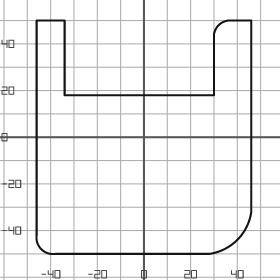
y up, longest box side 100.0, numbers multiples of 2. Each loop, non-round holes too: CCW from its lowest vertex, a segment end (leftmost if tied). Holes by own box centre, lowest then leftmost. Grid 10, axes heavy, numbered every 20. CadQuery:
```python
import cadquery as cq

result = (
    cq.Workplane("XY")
    .moveTo(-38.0, -50.0)
    .lineTo(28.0, -50.0)
    .threePointArc((40.0, -44.0), (46.0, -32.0))
    .lineTo(46.0, 50.0)
    .lineTo(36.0, 50.0)
    .threePointArc((32.0, 48.0), (30.0, 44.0))
    .lineTo(30.0, 18.0)
    .lineTo(-34.0, 18.0)
    .lineTo(-34.0, 50.0)
    .lineTo(-46.0, 50.0)
    .lineTo(-46.0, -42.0)
    .threePointArc((-44.0, -48.0), (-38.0, -50.0))
    .close()
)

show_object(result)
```